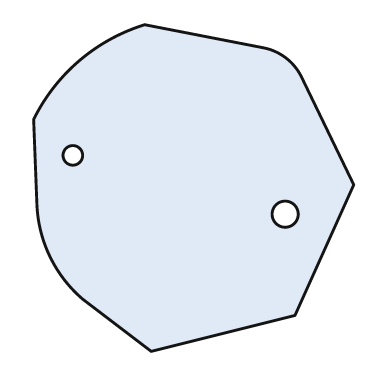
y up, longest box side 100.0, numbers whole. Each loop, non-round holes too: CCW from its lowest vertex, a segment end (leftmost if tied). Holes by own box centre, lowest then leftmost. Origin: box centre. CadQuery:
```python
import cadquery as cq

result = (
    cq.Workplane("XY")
    .moveTo(-13.0, -50.0)
    .lineTo(31.0, -39.0)
    .lineTo(49.0, 1.0)
    .lineTo(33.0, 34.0)
    .threePointArc((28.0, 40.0), (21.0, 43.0))
    .lineTo(-15.0, 50.0)
    .threePointArc((-35.0, 39.0), (-49.0, 21.0))
    .lineTo(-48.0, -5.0)
    .threePointArc((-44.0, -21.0), (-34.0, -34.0))
    .close()
    .moveTo(28.0, -8.0)
    .circle(4.0)
    .moveTo(-37.0, 10.0)
    .circle(3.0)
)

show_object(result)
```